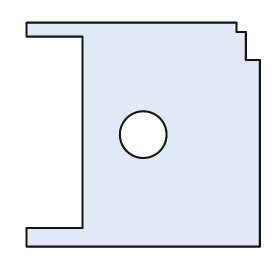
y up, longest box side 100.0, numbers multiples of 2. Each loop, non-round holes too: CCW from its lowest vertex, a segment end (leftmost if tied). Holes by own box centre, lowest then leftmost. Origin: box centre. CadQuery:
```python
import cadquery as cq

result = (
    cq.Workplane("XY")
    .moveTo(-50.0, -48.0)
    .lineTo(50.0, -48.0)
    .lineTo(50.0, 32.0)
    .lineTo(44.0, 32.0)
    .lineTo(44.0, 44.0)
    .lineTo(40.0, 44.0)
    .lineTo(40.0, 48.0)
    .lineTo(-50.0, 48.0)
    .lineTo(-50.0, 42.0)
    .lineTo(-26.0, 42.0)
    .lineTo(-26.0, -40.0)
    .lineTo(-50.0, -40.0)
    .close()
    .moveTo(0.0, 0.0)
    .circle(10.0)
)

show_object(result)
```